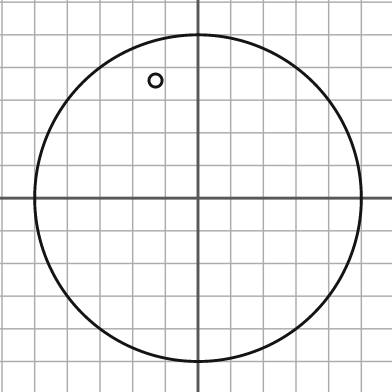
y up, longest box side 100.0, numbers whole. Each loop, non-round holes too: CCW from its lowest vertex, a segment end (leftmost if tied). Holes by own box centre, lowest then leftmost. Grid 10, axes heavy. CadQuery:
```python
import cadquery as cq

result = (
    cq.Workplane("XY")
    .moveTo(0.0, 0.0)
    .circle(50.0)
    .moveTo(-13.0, 36.0)
    .circle(2.0)
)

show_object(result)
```